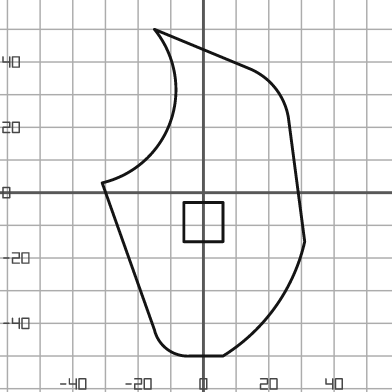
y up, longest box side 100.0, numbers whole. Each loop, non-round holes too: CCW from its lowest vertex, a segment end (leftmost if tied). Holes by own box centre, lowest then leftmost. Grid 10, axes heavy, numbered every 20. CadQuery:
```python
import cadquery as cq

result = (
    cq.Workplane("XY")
    .moveTo(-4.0, -50.0)
    .lineTo(6.0, -50.0)
    .threePointArc((22.0, -35.0), (31.0, -15.0))
    .lineTo(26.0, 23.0)
    .threePointArc((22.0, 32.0), (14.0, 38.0))
    .lineTo(-15.0, 50.0)
    .threePointArc((-10.0, 22.0), (-31.0, 3.0))
    .lineTo(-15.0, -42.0)
    .threePointArc((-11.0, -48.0), (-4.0, -50.0))
    .close()
    .moveTo(-6.0, -15.0)
    .lineTo(6.0, -15.0)
    .lineTo(6.0, -3.0)
    .lineTo(-6.0, -3.0)
    .close()
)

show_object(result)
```